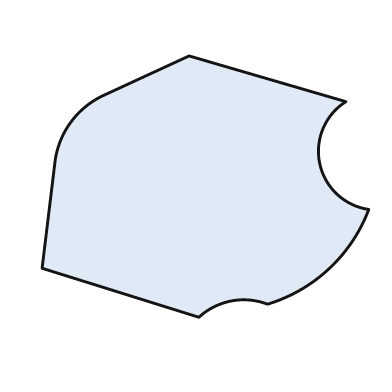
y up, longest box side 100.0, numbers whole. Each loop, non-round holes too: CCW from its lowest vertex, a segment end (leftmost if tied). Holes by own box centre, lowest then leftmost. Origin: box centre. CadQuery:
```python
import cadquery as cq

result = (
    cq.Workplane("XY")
    .moveTo(-2.0, -40.0)
    .threePointArc((8.0, -35.0), (19.0, -36.0))
    .threePointArc((38.0, -25.0), (50.0, -7.0))
    .threePointArc((35.0, 7.0), (43.0, 26.0))
    .lineTo(-5.0, 40.0)
    .lineTo(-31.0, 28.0)
    .threePointArc((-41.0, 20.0), (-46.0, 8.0))
    .lineTo(-50.0, -25.0)
    .close()
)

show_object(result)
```